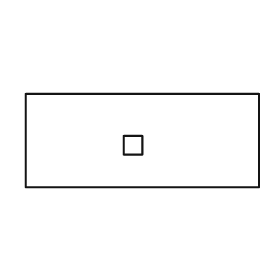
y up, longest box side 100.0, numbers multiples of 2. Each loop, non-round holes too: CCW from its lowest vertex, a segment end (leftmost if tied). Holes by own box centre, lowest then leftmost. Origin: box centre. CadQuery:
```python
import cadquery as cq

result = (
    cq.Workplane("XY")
    .moveTo(-50.0, -20.0)
    .lineTo(50.0, -20.0)
    .lineTo(50.0, 20.0)
    .lineTo(-50.0, 20.0)
    .close()
    .moveTo(-8.0, -6.0)
    .lineTo(0.0, -6.0)
    .lineTo(0.0, 2.0)
    .lineTo(-8.0, 2.0)
    .close()
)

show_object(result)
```